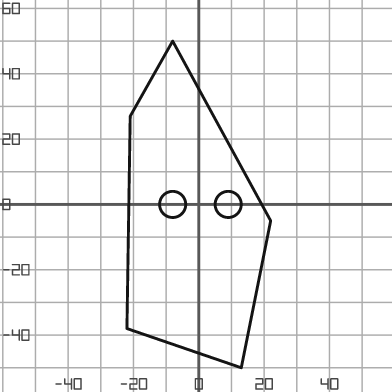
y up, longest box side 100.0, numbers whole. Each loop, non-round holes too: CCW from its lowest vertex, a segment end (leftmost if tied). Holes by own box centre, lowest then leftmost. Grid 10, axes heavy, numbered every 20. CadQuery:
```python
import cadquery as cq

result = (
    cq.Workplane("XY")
    .moveTo(13.0, -50.0)
    .lineTo(22.0, -5.0)
    .lineTo(-8.0, 50.0)
    .lineTo(-21.0, 27.0)
    .lineTo(-22.0, -38.0)
    .close()
    .moveTo(-8.0, 0.0)
    .circle(4.0)
    .moveTo(9.0, 0.0)
    .circle(4.0)
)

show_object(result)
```